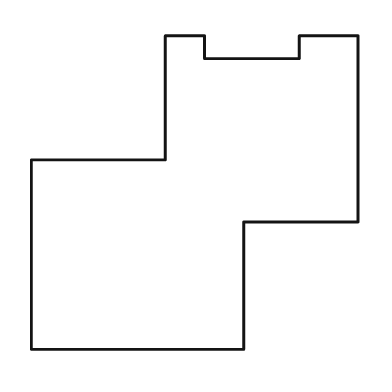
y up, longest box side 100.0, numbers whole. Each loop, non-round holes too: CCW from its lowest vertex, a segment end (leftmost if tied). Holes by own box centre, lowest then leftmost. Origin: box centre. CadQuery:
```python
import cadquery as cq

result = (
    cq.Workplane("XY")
    .moveTo(-50.0, -48.0)
    .lineTo(15.0, -48.0)
    .lineTo(15.0, -9.0)
    .lineTo(50.0, -9.0)
    .lineTo(50.0, 48.0)
    .lineTo(32.0, 48.0)
    .lineTo(32.0, 41.0)
    .lineTo(3.0, 41.0)
    .lineTo(3.0, 48.0)
    .lineTo(-9.0, 48.0)
    .lineTo(-9.0, 10.0)
    .lineTo(-50.0, 10.0)
    .close()
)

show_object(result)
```